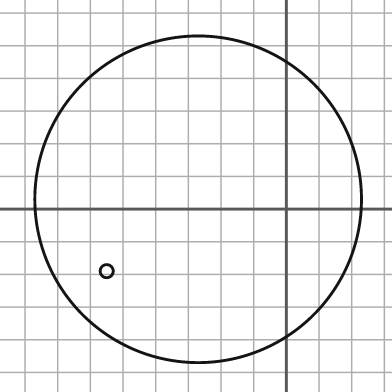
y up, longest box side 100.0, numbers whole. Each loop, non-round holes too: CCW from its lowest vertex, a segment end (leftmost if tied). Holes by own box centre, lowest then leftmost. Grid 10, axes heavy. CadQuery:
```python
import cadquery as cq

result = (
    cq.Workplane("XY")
    .moveTo(-27.0, 3.0)
    .circle(50.0)
    .moveTo(-55.0, -19.0)
    .circle(2.0)
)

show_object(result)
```